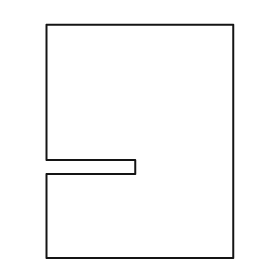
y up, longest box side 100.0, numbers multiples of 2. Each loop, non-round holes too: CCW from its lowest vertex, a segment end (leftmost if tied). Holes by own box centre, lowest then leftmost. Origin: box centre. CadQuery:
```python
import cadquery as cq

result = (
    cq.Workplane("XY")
    .moveTo(-40.0, -50.0)
    .lineTo(40.0, -50.0)
    .lineTo(40.0, 50.0)
    .lineTo(-40.0, 50.0)
    .lineTo(-40.0, -8.0)
    .lineTo(-2.0, -8.0)
    .lineTo(-2.0, -14.0)
    .lineTo(-40.0, -14.0)
    .close()
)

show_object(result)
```